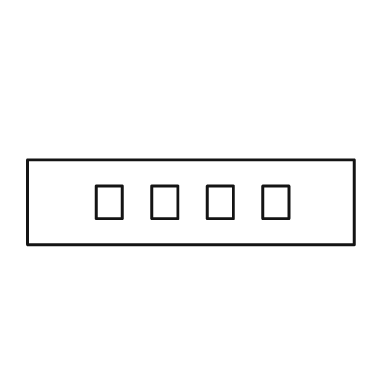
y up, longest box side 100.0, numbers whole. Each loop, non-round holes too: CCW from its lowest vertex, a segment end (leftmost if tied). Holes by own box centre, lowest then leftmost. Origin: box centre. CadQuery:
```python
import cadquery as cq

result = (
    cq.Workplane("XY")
    .moveTo(-50.0, -13.0)
    .lineTo(50.0, -13.0)
    .lineTo(50.0, 13.0)
    .lineTo(-50.0, 13.0)
    .close()
    .moveTo(-29.0, -5.0)
    .lineTo(-21.0, -5.0)
    .lineTo(-21.0, 5.0)
    .lineTo(-29.0, 5.0)
    .close()
    .moveTo(-12.0, -5.0)
    .lineTo(-4.0, -5.0)
    .lineTo(-4.0, 5.0)
    .lineTo(-12.0, 5.0)
    .close()
    .moveTo(5.0, -5.0)
    .lineTo(13.0, -5.0)
    .lineTo(13.0, 5.0)
    .lineTo(5.0, 5.0)
    .close()
    .moveTo(22.0, -5.0)
    .lineTo(30.0, -5.0)
    .lineTo(30.0, 5.0)
    .lineTo(22.0, 5.0)
    .close()
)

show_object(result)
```